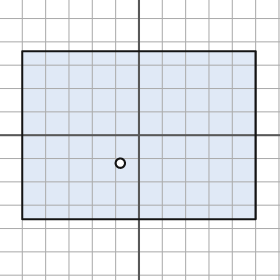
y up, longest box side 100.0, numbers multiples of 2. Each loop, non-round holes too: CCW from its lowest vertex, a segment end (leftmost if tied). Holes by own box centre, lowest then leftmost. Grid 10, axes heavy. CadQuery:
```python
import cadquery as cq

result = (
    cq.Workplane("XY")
    .moveTo(-50.0, -36.0)
    .lineTo(50.0, -36.0)
    .lineTo(50.0, 36.0)
    .lineTo(-50.0, 36.0)
    .close()
    .moveTo(-8.0, -12.0)
    .circle(2.0)
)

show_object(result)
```